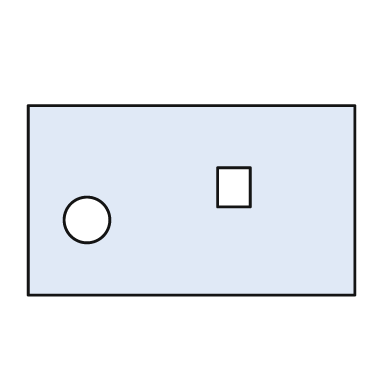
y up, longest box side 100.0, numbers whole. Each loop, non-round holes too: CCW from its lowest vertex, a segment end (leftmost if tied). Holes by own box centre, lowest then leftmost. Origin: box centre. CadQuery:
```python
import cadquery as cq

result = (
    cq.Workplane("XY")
    .moveTo(-50.0, -29.0)
    .lineTo(50.0, -29.0)
    .lineTo(50.0, 29.0)
    .lineTo(-50.0, 29.0)
    .close()
    .moveTo(-32.0, -6.0)
    .circle(7.0)
    .moveTo(8.0, -2.0)
    .lineTo(18.0, -2.0)
    .lineTo(18.0, 10.0)
    .lineTo(8.0, 10.0)
    .close()
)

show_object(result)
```